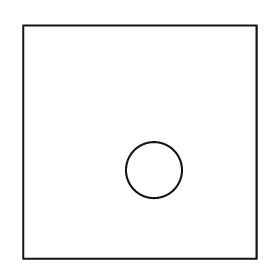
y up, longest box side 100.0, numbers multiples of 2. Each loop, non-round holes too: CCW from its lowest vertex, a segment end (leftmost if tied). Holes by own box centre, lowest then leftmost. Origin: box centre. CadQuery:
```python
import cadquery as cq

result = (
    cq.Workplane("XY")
    .moveTo(-50.0, -50.0)
    .lineTo(50.0, -50.0)
    .lineTo(50.0, 50.0)
    .lineTo(-50.0, 50.0)
    .close()
    .moveTo(6.0, -12.0)
    .circle(12.0)
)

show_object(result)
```